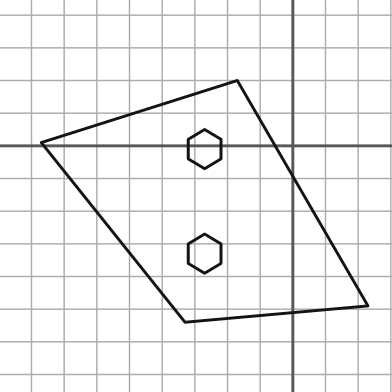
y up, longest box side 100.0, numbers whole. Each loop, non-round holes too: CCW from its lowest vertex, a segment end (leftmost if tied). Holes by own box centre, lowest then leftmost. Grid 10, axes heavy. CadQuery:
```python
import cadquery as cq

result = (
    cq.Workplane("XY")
    .moveTo(-33.0, -54.0)
    .lineTo(23.0, -49.0)
    .lineTo(-17.0, 20.0)
    .lineTo(-77.0, 1.0)
    .close()
    .moveTo(-27.0, -39.0)
    .lineTo(-22.0, -36.0)
    .lineTo(-22.0, -30.0)
    .lineTo(-27.0, -27.0)
    .lineTo(-32.0, -30.0)
    .lineTo(-32.0, -36.0)
    .close()
    .moveTo(-27.0, -7.0)
    .lineTo(-22.0, -4.0)
    .lineTo(-22.0, 2.0)
    .lineTo(-27.0, 5.0)
    .lineTo(-32.0, 2.0)
    .lineTo(-32.0, -4.0)
    .close()
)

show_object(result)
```